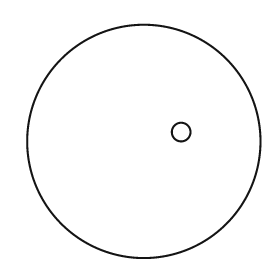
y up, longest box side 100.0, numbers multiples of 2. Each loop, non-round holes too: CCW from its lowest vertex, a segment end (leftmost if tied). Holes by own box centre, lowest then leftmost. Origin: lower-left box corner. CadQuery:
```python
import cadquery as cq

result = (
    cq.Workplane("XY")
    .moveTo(50.0, 50.0)
    .circle(50.0)
    .moveTo(66.0, 54.0)
    .circle(4.0)
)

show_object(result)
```